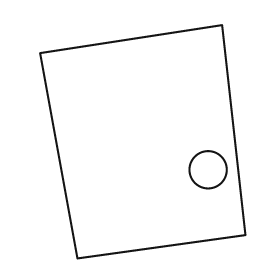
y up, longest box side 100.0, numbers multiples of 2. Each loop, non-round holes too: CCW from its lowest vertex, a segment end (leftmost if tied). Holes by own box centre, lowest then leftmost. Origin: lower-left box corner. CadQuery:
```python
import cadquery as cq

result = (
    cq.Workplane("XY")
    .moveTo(16.0, 0.0)
    .lineTo(88.0, 10.0)
    .lineTo(78.0, 100.0)
    .lineTo(0.0, 88.0)
    .close()
    .moveTo(72.0, 38.0)
    .circle(8.0)
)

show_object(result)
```